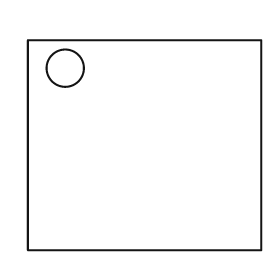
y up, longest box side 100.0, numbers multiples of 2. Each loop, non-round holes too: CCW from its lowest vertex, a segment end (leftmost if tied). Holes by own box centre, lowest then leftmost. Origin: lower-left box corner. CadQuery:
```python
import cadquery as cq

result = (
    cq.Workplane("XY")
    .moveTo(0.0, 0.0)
    .lineTo(100.0, 0.0)
    .lineTo(100.0, 90.0)
    .lineTo(0.0, 90.0)
    .close()
    .moveTo(16.0, 78.0)
    .circle(8.0)
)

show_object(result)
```